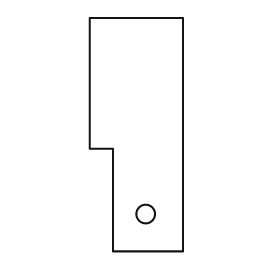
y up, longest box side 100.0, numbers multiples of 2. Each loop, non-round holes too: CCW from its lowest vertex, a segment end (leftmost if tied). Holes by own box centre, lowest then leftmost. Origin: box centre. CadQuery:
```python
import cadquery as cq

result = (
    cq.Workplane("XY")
    .moveTo(-10.0, -50.0)
    .lineTo(20.0, -50.0)
    .lineTo(20.0, 50.0)
    .lineTo(-20.0, 50.0)
    .lineTo(-20.0, -6.0)
    .lineTo(-10.0, -6.0)
    .close()
    .moveTo(4.0, -34.0)
    .circle(4.0)
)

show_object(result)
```